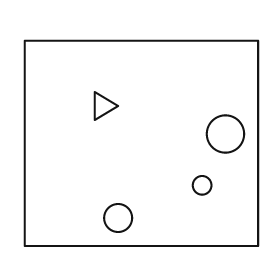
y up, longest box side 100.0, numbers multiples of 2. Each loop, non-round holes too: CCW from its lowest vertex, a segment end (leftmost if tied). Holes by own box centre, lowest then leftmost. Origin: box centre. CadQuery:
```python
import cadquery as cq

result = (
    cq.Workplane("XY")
    .moveTo(-50.0, -44.0)
    .lineTo(50.0, -44.0)
    .lineTo(50.0, 44.0)
    .lineTo(-50.0, 44.0)
    .close()
    .moveTo(-10.0, -32.0)
    .circle(6.0)
    .moveTo(26.0, -18.0)
    .circle(4.0)
    .moveTo(36.0, 4.0)
    .circle(8.0)
    .moveTo(-20.0, 10.0)
    .lineTo(-10.0, 16.0)
    .lineTo(-20.0, 22.0)
    .close()
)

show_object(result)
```